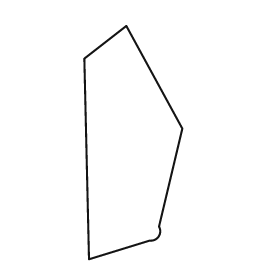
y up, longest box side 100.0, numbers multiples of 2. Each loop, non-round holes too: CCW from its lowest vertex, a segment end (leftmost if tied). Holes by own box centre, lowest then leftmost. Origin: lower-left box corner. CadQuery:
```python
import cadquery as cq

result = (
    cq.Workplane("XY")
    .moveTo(2.0, 0.0)
    .lineTo(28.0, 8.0)
    .threePointArc((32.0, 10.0), (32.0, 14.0))
    .lineTo(42.0, 56.0)
    .lineTo(18.0, 100.0)
    .lineTo(0.0, 86.0)
    .close()
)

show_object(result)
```